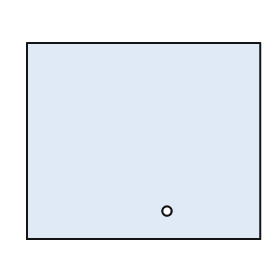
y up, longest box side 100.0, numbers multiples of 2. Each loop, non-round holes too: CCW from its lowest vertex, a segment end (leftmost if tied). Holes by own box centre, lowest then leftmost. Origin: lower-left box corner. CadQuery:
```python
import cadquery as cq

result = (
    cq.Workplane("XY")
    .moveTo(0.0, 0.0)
    .lineTo(100.0, 0.0)
    .lineTo(100.0, 84.0)
    .lineTo(0.0, 84.0)
    .close()
    .moveTo(60.0, 12.0)
    .circle(2.0)
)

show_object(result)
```